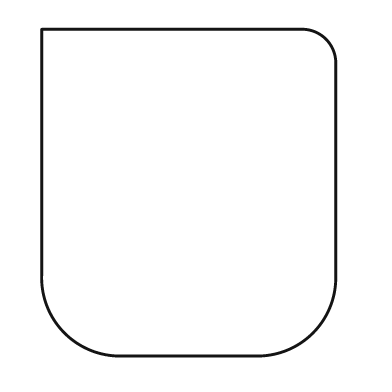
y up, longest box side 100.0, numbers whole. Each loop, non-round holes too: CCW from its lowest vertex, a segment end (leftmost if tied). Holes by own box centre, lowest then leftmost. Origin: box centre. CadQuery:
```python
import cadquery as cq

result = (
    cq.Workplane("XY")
    .moveTo(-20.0, -50.0)
    .lineTo(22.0, -50.0)
    .threePointArc((38.0, -43.0), (45.0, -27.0))
    .lineTo(45.0, 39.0)
    .threePointArc((42.0, 47.0), (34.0, 50.0))
    .lineTo(-45.0, 50.0)
    .lineTo(-45.0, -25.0)
    .threePointArc((-38.0, -43.0), (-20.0, -50.0))
    .close()
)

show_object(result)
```